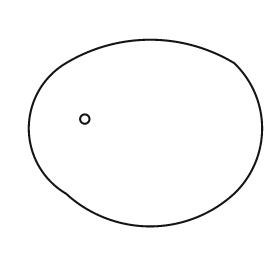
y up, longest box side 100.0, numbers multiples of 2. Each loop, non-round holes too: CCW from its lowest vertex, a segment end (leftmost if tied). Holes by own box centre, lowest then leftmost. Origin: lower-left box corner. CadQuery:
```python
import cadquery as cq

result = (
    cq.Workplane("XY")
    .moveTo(16.0, 14.0)
    .threePointArc((52.0, 0.0), (88.0, 14.0))
    .threePointArc((100.0, 42.0), (88.0, 70.0))
    .threePointArc((52.0, 80.0), (16.0, 70.0))
    .threePointArc((0.0, 42.0), (16.0, 14.0))
    .close()
    .moveTo(24.0, 46.0)
    .circle(2.0)
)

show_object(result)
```